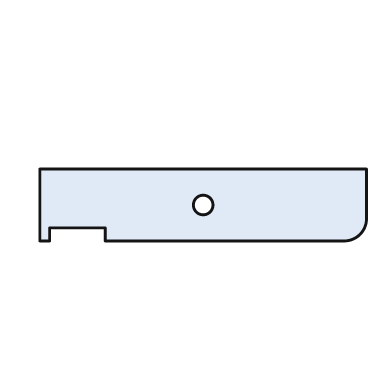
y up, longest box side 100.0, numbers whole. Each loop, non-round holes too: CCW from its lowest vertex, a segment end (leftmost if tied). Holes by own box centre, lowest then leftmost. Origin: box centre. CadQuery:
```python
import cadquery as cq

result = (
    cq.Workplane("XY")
    .moveTo(-50.0, -11.0)
    .lineTo(-47.0, -11.0)
    .lineTo(-47.0, -7.0)
    .lineTo(-30.0, -7.0)
    .lineTo(-30.0, -11.0)
    .lineTo(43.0, -11.0)
    .threePointArc((48.0, -9.0), (50.0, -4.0))
    .lineTo(50.0, 11.0)
    .lineTo(-50.0, 11.0)
    .close()
    .moveTo(0.0, 0.0)
    .circle(3.0)
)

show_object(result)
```